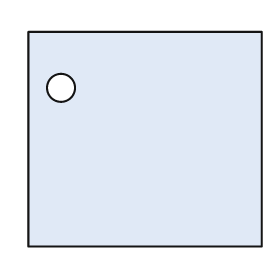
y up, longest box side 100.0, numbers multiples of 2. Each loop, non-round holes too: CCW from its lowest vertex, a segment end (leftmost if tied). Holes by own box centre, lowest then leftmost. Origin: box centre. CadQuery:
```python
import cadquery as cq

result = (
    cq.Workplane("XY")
    .moveTo(-50.0, -46.0)
    .lineTo(50.0, -46.0)
    .lineTo(50.0, 46.0)
    .lineTo(-50.0, 46.0)
    .close()
    .moveTo(-36.0, 22.0)
    .circle(6.0)
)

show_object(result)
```